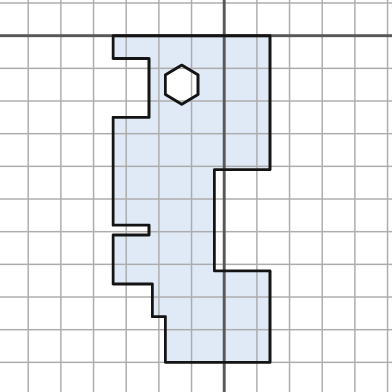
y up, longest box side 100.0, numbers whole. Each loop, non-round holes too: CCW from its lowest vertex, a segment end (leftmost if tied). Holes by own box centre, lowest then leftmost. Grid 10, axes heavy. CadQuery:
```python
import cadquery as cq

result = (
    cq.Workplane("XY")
    .moveTo(-18.0, -100.0)
    .lineTo(14.0, -100.0)
    .lineTo(14.0, -72.0)
    .lineTo(-3.0, -72.0)
    .lineTo(-3.0, -41.0)
    .lineTo(14.0, -41.0)
    .lineTo(14.0, 0.0)
    .lineTo(-34.0, 0.0)
    .lineTo(-34.0, -7.0)
    .lineTo(-23.0, -7.0)
    .lineTo(-23.0, -25.0)
    .lineTo(-34.0, -25.0)
    .lineTo(-34.0, -58.0)
    .lineTo(-23.0, -58.0)
    .lineTo(-23.0, -61.0)
    .lineTo(-34.0, -61.0)
    .lineTo(-34.0, -76.0)
    .lineTo(-22.0, -76.0)
    .lineTo(-22.0, -86.0)
    .lineTo(-18.0, -86.0)
    .close()
    .moveTo(-13.0, -21.0)
    .lineTo(-8.0, -18.0)
    .lineTo(-8.0, -12.0)
    .lineTo(-13.0, -9.0)
    .lineTo(-18.0, -12.0)
    .lineTo(-18.0, -18.0)
    .close()
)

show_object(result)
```